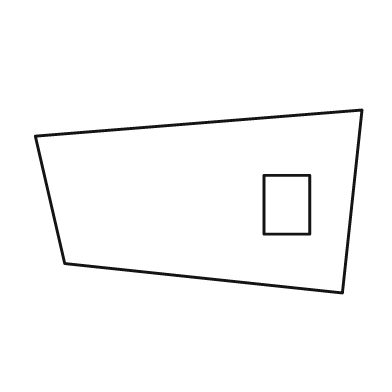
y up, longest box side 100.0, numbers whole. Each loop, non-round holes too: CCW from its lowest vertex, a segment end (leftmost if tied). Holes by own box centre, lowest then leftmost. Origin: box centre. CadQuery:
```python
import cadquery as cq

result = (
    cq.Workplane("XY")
    .moveTo(44.0, -28.0)
    .lineTo(50.0, 28.0)
    .lineTo(-50.0, 20.0)
    .lineTo(-41.0, -19.0)
    .close()
    .moveTo(20.0, -10.0)
    .lineTo(34.0, -10.0)
    .lineTo(34.0, 8.0)
    .lineTo(20.0, 8.0)
    .close()
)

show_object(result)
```